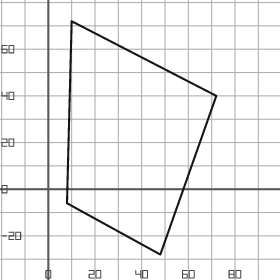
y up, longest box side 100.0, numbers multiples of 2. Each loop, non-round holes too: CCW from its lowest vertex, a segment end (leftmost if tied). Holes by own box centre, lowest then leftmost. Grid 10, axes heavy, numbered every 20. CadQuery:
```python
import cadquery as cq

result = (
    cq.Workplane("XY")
    .moveTo(48.0, -28.0)
    .lineTo(72.0, 40.0)
    .lineTo(10.0, 72.0)
    .lineTo(8.0, -6.0)
    .close()
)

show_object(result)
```